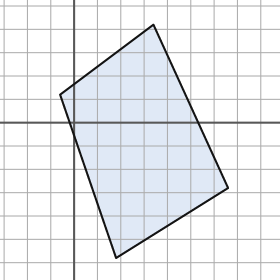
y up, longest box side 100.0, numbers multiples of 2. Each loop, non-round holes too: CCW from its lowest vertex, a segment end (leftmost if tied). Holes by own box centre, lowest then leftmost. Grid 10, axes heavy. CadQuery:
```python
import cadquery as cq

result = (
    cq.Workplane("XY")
    .moveTo(18.0, -58.0)
    .lineTo(66.0, -28.0)
    .lineTo(34.0, 42.0)
    .lineTo(-6.0, 12.0)
    .close()
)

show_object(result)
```